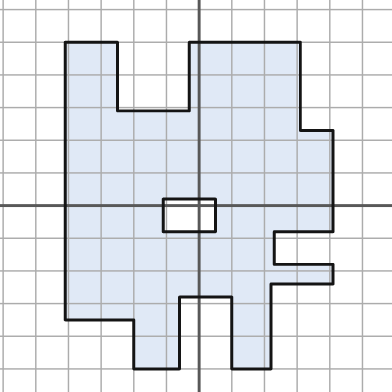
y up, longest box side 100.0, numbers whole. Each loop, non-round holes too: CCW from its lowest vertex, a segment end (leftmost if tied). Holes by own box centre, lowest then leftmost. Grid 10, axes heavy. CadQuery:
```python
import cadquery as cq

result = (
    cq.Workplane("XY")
    .moveTo(-20.0, -50.0)
    .lineTo(-6.0, -50.0)
    .lineTo(-6.0, -28.0)
    .lineTo(10.0, -28.0)
    .lineTo(10.0, -50.0)
    .lineTo(22.0, -50.0)
    .lineTo(22.0, -24.0)
    .lineTo(41.0, -24.0)
    .lineTo(41.0, -18.0)
    .lineTo(23.0, -18.0)
    .lineTo(23.0, -8.0)
    .lineTo(41.0, -8.0)
    .lineTo(41.0, 23.0)
    .lineTo(31.0, 23.0)
    .lineTo(31.0, 50.0)
    .lineTo(-3.0, 50.0)
    .lineTo(-3.0, 29.0)
    .lineTo(-25.0, 29.0)
    .lineTo(-25.0, 50.0)
    .lineTo(-41.0, 50.0)
    .lineTo(-41.0, -35.0)
    .lineTo(-20.0, -35.0)
    .close()
    .moveTo(-11.0, -8.0)
    .lineTo(5.0, -8.0)
    .lineTo(5.0, 2.0)
    .lineTo(-11.0, 2.0)
    .close()
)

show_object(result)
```